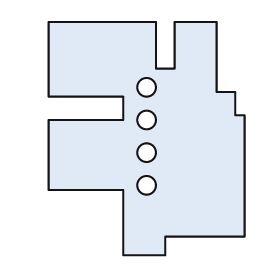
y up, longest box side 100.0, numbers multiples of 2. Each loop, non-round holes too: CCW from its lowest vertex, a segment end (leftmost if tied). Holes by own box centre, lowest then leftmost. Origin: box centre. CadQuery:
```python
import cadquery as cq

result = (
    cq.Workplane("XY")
    .moveTo(-10.0, -50.0)
    .lineTo(8.0, -50.0)
    .lineTo(8.0, -42.0)
    .lineTo(42.0, -42.0)
    .lineTo(42.0, 10.0)
    .lineTo(38.0, 10.0)
    .lineTo(38.0, 20.0)
    .lineTo(30.0, 20.0)
    .lineTo(30.0, 50.0)
    .lineTo(12.0, 50.0)
    .lineTo(12.0, 30.0)
    .lineTo(4.0, 30.0)
    .lineTo(4.0, 50.0)
    .lineTo(-42.0, 50.0)
    .lineTo(-42.0, 18.0)
    .lineTo(-10.0, 18.0)
    .lineTo(-10.0, 8.0)
    .lineTo(-42.0, 8.0)
    .lineTo(-42.0, -22.0)
    .lineTo(-10.0, -22.0)
    .close()
    .moveTo(0.0, -20.0)
    .circle(4.0)
    .moveTo(0.0, -6.0)
    .circle(4.0)
    .moveTo(0.0, 8.0)
    .circle(4.0)
    .moveTo(0.0, 22.0)
    .circle(4.0)
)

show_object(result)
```